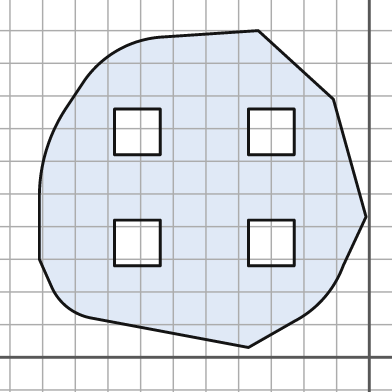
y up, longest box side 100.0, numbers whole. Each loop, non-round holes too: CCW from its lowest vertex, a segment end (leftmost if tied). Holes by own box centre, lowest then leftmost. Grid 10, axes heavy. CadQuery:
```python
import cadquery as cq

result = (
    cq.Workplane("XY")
    .moveTo(-37.0, 3.0)
    .lineTo(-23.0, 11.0)
    .threePointArc((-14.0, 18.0), (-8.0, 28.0))
    .lineTo(-1.0, 43.0)
    .lineTo(-11.0, 79.0)
    .lineTo(-34.0, 100.0)
    .lineTo(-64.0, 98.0)
    .threePointArc((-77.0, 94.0), (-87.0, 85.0))
    .lineTo(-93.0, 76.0)
    .threePointArc((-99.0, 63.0), (-101.0, 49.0))
    .lineTo(-101.0, 30.0)
    .lineTo(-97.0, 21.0)
    .threePointArc((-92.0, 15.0), (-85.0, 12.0))
    .close()
    .moveTo(-78.0, 28.0)
    .lineTo(-64.0, 28.0)
    .lineTo(-64.0, 42.0)
    .lineTo(-78.0, 42.0)
    .close()
    .moveTo(-37.0, 28.0)
    .lineTo(-23.0, 28.0)
    .lineTo(-23.0, 42.0)
    .lineTo(-37.0, 42.0)
    .close()
    .moveTo(-78.0, 62.0)
    .lineTo(-64.0, 62.0)
    .lineTo(-64.0, 76.0)
    .lineTo(-78.0, 76.0)
    .close()
    .moveTo(-37.0, 62.0)
    .lineTo(-23.0, 62.0)
    .lineTo(-23.0, 76.0)
    .lineTo(-37.0, 76.0)
    .close()
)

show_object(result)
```